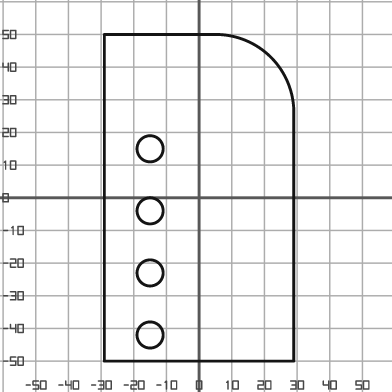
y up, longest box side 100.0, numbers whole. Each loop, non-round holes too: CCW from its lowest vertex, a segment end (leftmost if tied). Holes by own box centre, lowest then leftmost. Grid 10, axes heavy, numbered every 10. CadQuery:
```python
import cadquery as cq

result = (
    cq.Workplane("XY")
    .moveTo(-29.0, -50.0)
    .lineTo(29.0, -50.0)
    .lineTo(29.0, 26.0)
    .threePointArc((22.0, 43.0), (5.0, 50.0))
    .lineTo(-29.0, 50.0)
    .close()
    .moveTo(-15.0, -42.0)
    .circle(4.0)
    .moveTo(-15.0, -23.0)
    .circle(4.0)
    .moveTo(-15.0, -4.0)
    .circle(4.0)
    .moveTo(-15.0, 15.0)
    .circle(4.0)
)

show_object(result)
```